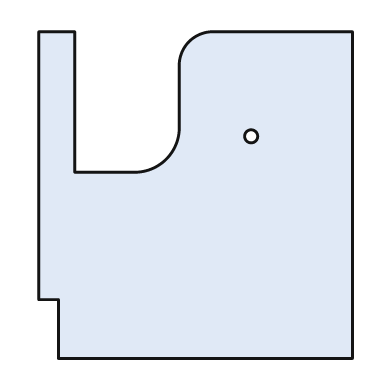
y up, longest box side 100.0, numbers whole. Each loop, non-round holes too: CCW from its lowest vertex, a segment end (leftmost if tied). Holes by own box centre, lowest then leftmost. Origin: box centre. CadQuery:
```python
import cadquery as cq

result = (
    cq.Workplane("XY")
    .moveTo(-42.0, -50.0)
    .lineTo(48.0, -50.0)
    .lineTo(48.0, 50.0)
    .lineTo(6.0, 50.0)
    .threePointArc((-2.0, 47.0), (-5.0, 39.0))
    .lineTo(-5.0, 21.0)
    .threePointArc((-9.0, 11.0), (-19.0, 7.0))
    .lineTo(-37.0, 7.0)
    .lineTo(-37.0, 50.0)
    .lineTo(-48.0, 50.0)
    .lineTo(-48.0, -32.0)
    .lineTo(-42.0, -32.0)
    .close()
    .moveTo(17.0, 18.0)
    .circle(2.0)
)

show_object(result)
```